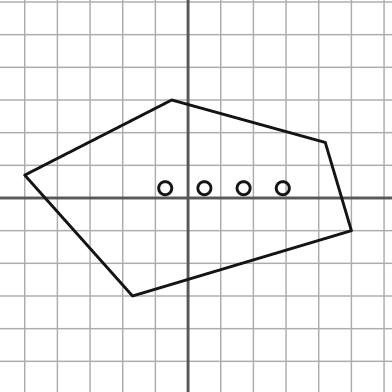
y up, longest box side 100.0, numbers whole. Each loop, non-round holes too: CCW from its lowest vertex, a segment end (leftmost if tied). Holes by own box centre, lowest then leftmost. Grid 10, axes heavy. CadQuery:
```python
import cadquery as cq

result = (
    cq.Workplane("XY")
    .moveTo(-17.0, -30.0)
    .lineTo(50.0, -10.0)
    .lineTo(42.0, 17.0)
    .lineTo(-5.0, 30.0)
    .lineTo(-50.0, 7.0)
    .close()
    .moveTo(-7.0, 3.0)
    .circle(2.0)
    .moveTo(5.0, 3.0)
    .circle(2.0)
    .moveTo(17.0, 3.0)
    .circle(2.0)
    .moveTo(29.0, 3.0)
    .circle(2.0)
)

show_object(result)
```